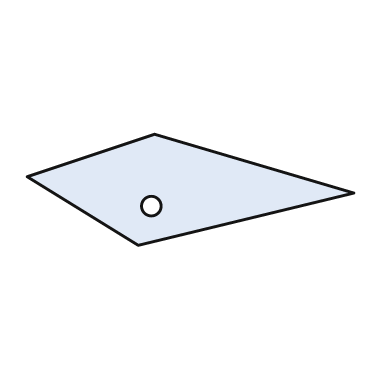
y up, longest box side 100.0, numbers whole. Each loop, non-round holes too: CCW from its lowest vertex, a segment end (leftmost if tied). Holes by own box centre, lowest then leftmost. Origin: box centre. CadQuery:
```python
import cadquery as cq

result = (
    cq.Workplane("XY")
    .moveTo(-16.0, -17.0)
    .lineTo(50.0, -1.0)
    .lineTo(-11.0, 17.0)
    .lineTo(-50.0, 4.0)
    .close()
    .moveTo(-12.0, -5.0)
    .circle(3.0)
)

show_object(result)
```